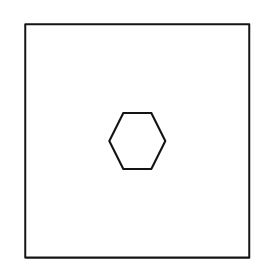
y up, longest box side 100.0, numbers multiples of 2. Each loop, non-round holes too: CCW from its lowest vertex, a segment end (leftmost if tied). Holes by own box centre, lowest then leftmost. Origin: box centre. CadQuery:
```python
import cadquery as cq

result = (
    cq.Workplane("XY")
    .moveTo(-48.0, -50.0)
    .lineTo(48.0, -50.0)
    .lineTo(48.0, 50.0)
    .lineTo(-48.0, 50.0)
    .close()
    .moveTo(-6.0, -12.0)
    .lineTo(6.0, -12.0)
    .lineTo(12.0, 0.0)
    .lineTo(6.0, 12.0)
    .lineTo(-6.0, 12.0)
    .lineTo(-12.0, 0.0)
    .close()
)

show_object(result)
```